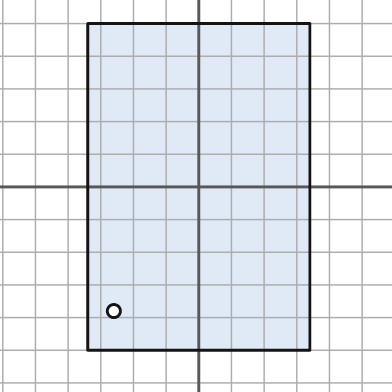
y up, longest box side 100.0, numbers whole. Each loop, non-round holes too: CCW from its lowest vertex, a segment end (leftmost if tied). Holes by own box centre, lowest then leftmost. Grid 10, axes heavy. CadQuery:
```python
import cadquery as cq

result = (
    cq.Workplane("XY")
    .moveTo(-34.0, -50.0)
    .lineTo(34.0, -50.0)
    .lineTo(34.0, 50.0)
    .lineTo(-34.0, 50.0)
    .close()
    .moveTo(-26.0, -38.0)
    .circle(2.0)
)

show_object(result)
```